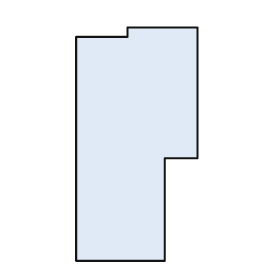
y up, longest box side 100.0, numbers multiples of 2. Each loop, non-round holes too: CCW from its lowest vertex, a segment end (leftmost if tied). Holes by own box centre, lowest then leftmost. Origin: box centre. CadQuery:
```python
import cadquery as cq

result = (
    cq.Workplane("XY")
    .moveTo(-26.0, -50.0)
    .lineTo(12.0, -50.0)
    .lineTo(12.0, -6.0)
    .lineTo(26.0, -6.0)
    .lineTo(26.0, 50.0)
    .lineTo(-4.0, 50.0)
    .lineTo(-4.0, 46.0)
    .lineTo(-26.0, 46.0)
    .close()
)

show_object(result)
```